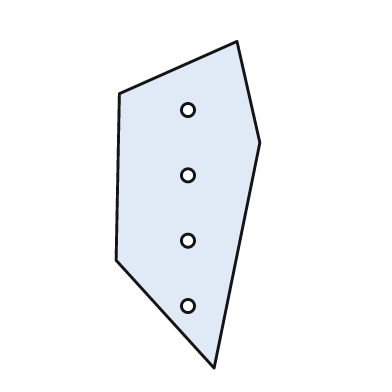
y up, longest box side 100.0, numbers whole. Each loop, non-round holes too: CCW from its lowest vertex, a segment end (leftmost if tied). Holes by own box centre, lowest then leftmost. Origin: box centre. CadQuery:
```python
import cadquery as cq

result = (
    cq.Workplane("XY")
    .moveTo(8.0, -50.0)
    .lineTo(22.0, 19.0)
    .lineTo(15.0, 50.0)
    .lineTo(-21.0, 34.0)
    .lineTo(-22.0, -17.0)
    .close()
    .moveTo(0.0, -31.0)
    .circle(2.0)
    .moveTo(0.0, -11.0)
    .circle(2.0)
    .moveTo(0.0, 9.0)
    .circle(2.0)
    .moveTo(0.0, 29.0)
    .circle(2.0)
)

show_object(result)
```